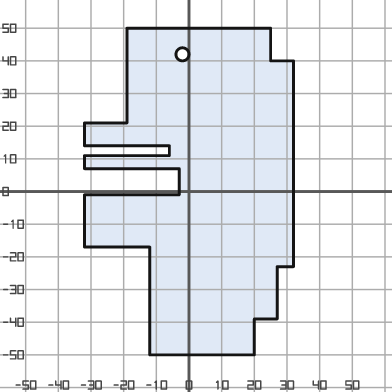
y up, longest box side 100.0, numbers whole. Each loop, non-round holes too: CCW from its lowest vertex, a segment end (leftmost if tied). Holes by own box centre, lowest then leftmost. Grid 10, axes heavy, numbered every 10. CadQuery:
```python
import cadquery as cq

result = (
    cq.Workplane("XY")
    .moveTo(-12.0, -50.0)
    .lineTo(20.0, -50.0)
    .lineTo(20.0, -39.0)
    .lineTo(27.0, -39.0)
    .lineTo(27.0, -23.0)
    .lineTo(32.0, -23.0)
    .lineTo(32.0, 40.0)
    .lineTo(25.0, 40.0)
    .lineTo(25.0, 50.0)
    .lineTo(-19.0, 50.0)
    .lineTo(-19.0, 21.0)
    .lineTo(-32.0, 21.0)
    .lineTo(-32.0, 14.0)
    .lineTo(-6.0, 14.0)
    .lineTo(-6.0, 11.0)
    .lineTo(-32.0, 11.0)
    .lineTo(-32.0, 7.0)
    .lineTo(-3.0, 7.0)
    .lineTo(-3.0, -1.0)
    .lineTo(-32.0, -1.0)
    .lineTo(-32.0, -17.0)
    .lineTo(-12.0, -17.0)
    .close()
    .moveTo(-2.0, 42.0)
    .circle(2.0)
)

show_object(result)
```